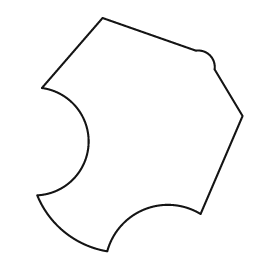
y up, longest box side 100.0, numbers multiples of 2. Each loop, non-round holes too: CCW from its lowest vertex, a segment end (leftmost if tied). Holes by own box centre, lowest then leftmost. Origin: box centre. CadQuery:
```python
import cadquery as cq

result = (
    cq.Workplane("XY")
    .moveTo(-14.0, -50.0)
    .threePointArc((2.0, -32.0), (26.0, -34.0))
    .lineTo(44.0, 8.0)
    .lineTo(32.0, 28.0)
    .threePointArc((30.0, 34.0), (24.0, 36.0))
    .lineTo(-16.0, 50.0)
    .lineTo(-42.0, 20.0)
    .threePointArc((-22.0, -4.0), (-44.0, -26.0))
    .threePointArc((-32.0, -42.0), (-14.0, -50.0))
    .close()
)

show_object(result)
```